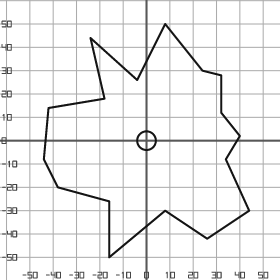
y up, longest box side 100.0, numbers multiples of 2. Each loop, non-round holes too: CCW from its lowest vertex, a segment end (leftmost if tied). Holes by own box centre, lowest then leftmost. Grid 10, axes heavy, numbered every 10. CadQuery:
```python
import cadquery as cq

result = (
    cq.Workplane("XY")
    .moveTo(-16.0, -50.0)
    .lineTo(8.0, -30.0)
    .lineTo(26.0, -42.0)
    .lineTo(44.0, -30.0)
    .lineTo(34.0, -8.0)
    .lineTo(40.0, 2.0)
    .lineTo(32.0, 12.0)
    .lineTo(32.0, 28.0)
    .lineTo(24.0, 30.0)
    .lineTo(8.0, 50.0)
    .lineTo(-4.0, 26.0)
    .lineTo(-24.0, 44.0)
    .lineTo(-18.0, 18.0)
    .lineTo(-42.0, 14.0)
    .lineTo(-44.0, -8.0)
    .lineTo(-38.0, -20.0)
    .lineTo(-16.0, -26.0)
    .close()
    .moveTo(0.0, 0.0)
    .circle(4.0)
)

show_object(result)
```